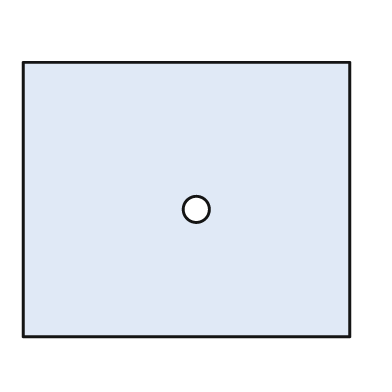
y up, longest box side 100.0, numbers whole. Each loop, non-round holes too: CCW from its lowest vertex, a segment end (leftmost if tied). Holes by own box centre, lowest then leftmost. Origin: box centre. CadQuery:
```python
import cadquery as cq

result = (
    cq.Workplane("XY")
    .moveTo(-50.0, -42.0)
    .lineTo(50.0, -42.0)
    .lineTo(50.0, 42.0)
    .lineTo(-50.0, 42.0)
    .close()
    .moveTo(3.0, -3.0)
    .circle(4.0)
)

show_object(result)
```